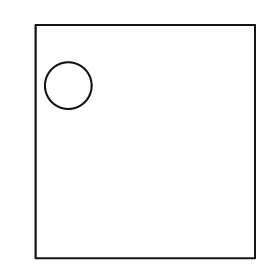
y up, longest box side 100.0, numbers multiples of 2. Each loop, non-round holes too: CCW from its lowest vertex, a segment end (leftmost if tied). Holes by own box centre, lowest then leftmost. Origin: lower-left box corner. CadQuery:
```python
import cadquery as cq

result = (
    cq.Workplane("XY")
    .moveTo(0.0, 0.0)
    .lineTo(94.0, 0.0)
    .lineTo(94.0, 100.0)
    .lineTo(0.0, 100.0)
    .close()
    .moveTo(14.0, 74.0)
    .circle(10.0)
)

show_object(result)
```